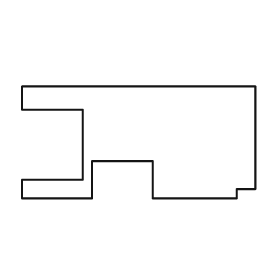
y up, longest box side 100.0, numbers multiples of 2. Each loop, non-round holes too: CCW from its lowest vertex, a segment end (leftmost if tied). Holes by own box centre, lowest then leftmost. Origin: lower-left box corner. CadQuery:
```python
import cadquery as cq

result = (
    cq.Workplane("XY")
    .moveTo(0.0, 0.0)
    .lineTo(30.0, 0.0)
    .lineTo(30.0, 16.0)
    .lineTo(56.0, 16.0)
    .lineTo(56.0, 0.0)
    .lineTo(92.0, 0.0)
    .lineTo(92.0, 4.0)
    .lineTo(100.0, 4.0)
    .lineTo(100.0, 48.0)
    .lineTo(0.0, 48.0)
    .lineTo(0.0, 38.0)
    .lineTo(26.0, 38.0)
    .lineTo(26.0, 8.0)
    .lineTo(0.0, 8.0)
    .close()
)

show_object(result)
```